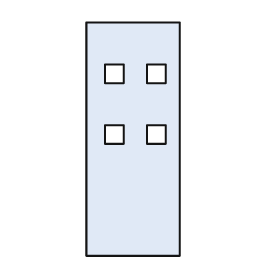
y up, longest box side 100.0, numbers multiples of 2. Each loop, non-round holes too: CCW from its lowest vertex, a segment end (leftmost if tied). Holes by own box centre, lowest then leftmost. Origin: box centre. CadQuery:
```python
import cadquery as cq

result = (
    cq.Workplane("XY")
    .moveTo(-20.0, -50.0)
    .lineTo(20.0, -50.0)
    .lineTo(20.0, 50.0)
    .lineTo(-20.0, 50.0)
    .close()
    .moveTo(-12.0, -2.0)
    .lineTo(-4.0, -2.0)
    .lineTo(-4.0, 6.0)
    .lineTo(-12.0, 6.0)
    .close()
    .moveTo(6.0, -2.0)
    .lineTo(14.0, -2.0)
    .lineTo(14.0, 6.0)
    .lineTo(6.0, 6.0)
    .close()
    .moveTo(-12.0, 24.0)
    .lineTo(-4.0, 24.0)
    .lineTo(-4.0, 32.0)
    .lineTo(-12.0, 32.0)
    .close()
    .moveTo(6.0, 24.0)
    .lineTo(14.0, 24.0)
    .lineTo(14.0, 32.0)
    .lineTo(6.0, 32.0)
    .close()
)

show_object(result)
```